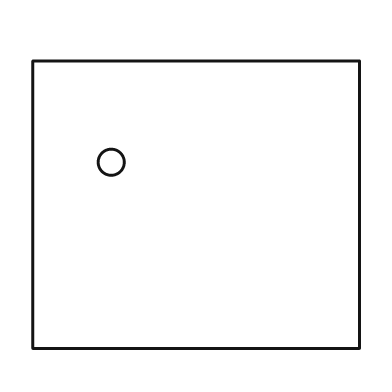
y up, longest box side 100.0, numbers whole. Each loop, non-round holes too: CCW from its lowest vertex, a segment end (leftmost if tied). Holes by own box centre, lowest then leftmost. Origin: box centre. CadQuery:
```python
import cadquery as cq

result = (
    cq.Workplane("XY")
    .moveTo(-50.0, -44.0)
    .lineTo(50.0, -44.0)
    .lineTo(50.0, 44.0)
    .lineTo(-50.0, 44.0)
    .close()
    .moveTo(-26.0, 13.0)
    .circle(4.0)
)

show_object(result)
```